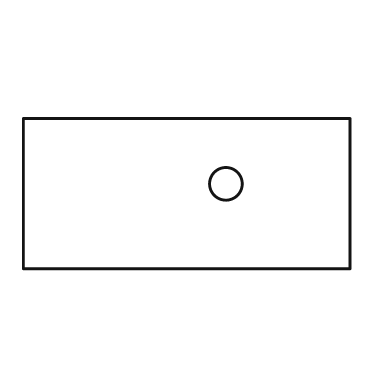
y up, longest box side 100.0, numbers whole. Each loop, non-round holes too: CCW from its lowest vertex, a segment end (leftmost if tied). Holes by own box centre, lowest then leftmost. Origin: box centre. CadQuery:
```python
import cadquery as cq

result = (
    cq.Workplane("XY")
    .moveTo(-50.0, -23.0)
    .lineTo(50.0, -23.0)
    .lineTo(50.0, 23.0)
    .lineTo(-50.0, 23.0)
    .close()
    .moveTo(12.0, 3.0)
    .circle(5.0)
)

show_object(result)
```